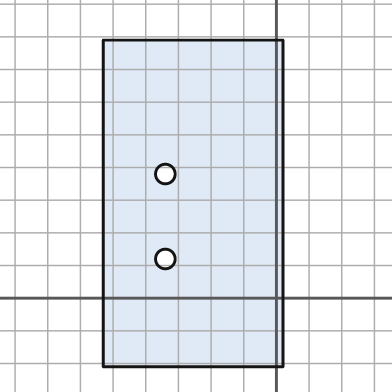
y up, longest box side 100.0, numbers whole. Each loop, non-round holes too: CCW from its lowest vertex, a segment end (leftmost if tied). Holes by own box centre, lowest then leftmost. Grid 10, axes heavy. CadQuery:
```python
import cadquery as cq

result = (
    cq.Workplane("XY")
    .moveTo(-53.0, -21.0)
    .lineTo(2.0, -21.0)
    .lineTo(2.0, 79.0)
    .lineTo(-53.0, 79.0)
    .close()
    .moveTo(-34.0, 12.0)
    .circle(3.0)
    .moveTo(-34.0, 38.0)
    .circle(3.0)
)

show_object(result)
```